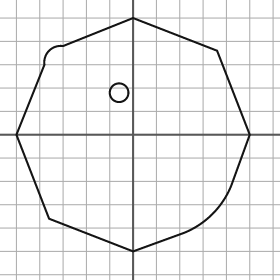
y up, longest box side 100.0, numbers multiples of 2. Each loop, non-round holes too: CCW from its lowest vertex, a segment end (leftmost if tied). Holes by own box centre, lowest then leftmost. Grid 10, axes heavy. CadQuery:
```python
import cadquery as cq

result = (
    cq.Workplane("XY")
    .moveTo(0.0, -50.0)
    .lineTo(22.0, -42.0)
    .threePointArc((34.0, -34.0), (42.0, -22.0))
    .lineTo(50.0, 0.0)
    .lineTo(36.0, 36.0)
    .lineTo(0.0, 50.0)
    .lineTo(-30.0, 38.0)
    .threePointArc((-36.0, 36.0), (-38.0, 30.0))
    .lineTo(-50.0, 0.0)
    .lineTo(-36.0, -36.0)
    .close()
    .moveTo(-6.0, 18.0)
    .circle(4.0)
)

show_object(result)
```